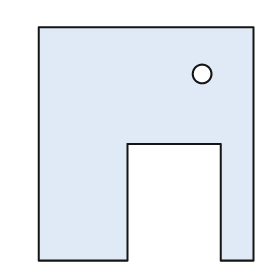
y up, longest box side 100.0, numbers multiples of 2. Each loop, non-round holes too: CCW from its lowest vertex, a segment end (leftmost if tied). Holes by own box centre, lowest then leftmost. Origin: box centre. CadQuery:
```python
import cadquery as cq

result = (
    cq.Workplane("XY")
    .moveTo(-46.0, -50.0)
    .lineTo(-8.0, -50.0)
    .lineTo(-8.0, 0.0)
    .lineTo(32.0, 0.0)
    .lineTo(32.0, -50.0)
    .lineTo(46.0, -50.0)
    .lineTo(46.0, 50.0)
    .lineTo(-46.0, 50.0)
    .close()
    .moveTo(24.0, 30.0)
    .circle(4.0)
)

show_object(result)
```